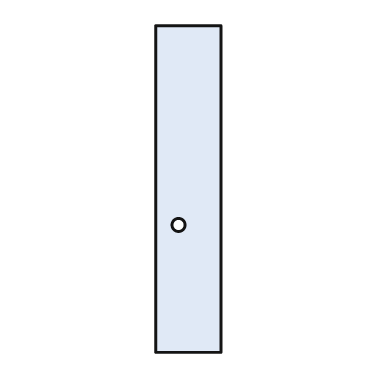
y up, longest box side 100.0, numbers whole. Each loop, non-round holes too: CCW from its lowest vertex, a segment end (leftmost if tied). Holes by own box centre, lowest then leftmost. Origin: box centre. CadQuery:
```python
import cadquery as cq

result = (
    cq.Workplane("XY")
    .moveTo(-10.0, -50.0)
    .lineTo(10.0, -50.0)
    .lineTo(10.0, 50.0)
    .lineTo(-10.0, 50.0)
    .close()
    .moveTo(-3.0, -11.0)
    .circle(2.0)
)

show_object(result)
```